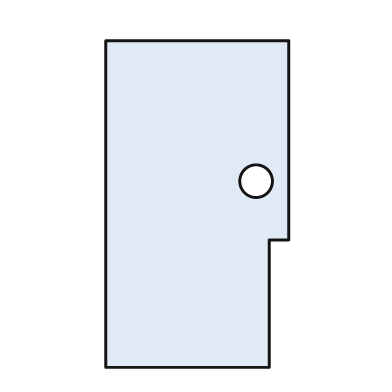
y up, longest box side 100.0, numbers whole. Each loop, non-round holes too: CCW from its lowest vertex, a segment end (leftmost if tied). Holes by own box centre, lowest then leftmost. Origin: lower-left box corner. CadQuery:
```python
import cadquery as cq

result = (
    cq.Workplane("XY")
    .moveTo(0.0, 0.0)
    .lineTo(50.0, 0.0)
    .lineTo(50.0, 39.0)
    .lineTo(56.0, 39.0)
    .lineTo(56.0, 100.0)
    .lineTo(0.0, 100.0)
    .close()
    .moveTo(46.0, 57.0)
    .circle(5.0)
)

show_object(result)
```